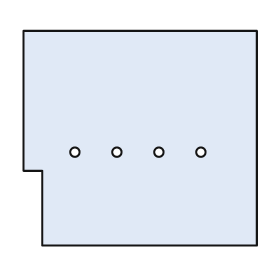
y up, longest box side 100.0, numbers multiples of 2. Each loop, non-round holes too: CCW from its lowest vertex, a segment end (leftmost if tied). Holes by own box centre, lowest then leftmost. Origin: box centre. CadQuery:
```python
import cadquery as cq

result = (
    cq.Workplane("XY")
    .moveTo(-42.0, -46.0)
    .lineTo(50.0, -46.0)
    .lineTo(50.0, 46.0)
    .lineTo(-50.0, 46.0)
    .lineTo(-50.0, -14.0)
    .lineTo(-42.0, -14.0)
    .close()
    .moveTo(-28.0, -6.0)
    .circle(2.0)
    .moveTo(-10.0, -6.0)
    .circle(2.0)
    .moveTo(8.0, -6.0)
    .circle(2.0)
    .moveTo(26.0, -6.0)
    .circle(2.0)
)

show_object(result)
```